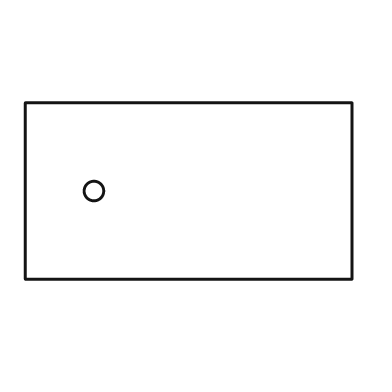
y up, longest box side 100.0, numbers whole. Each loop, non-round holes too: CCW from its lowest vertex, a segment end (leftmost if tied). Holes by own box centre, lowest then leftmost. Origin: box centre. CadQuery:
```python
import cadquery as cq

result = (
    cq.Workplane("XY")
    .moveTo(-50.0, -27.0)
    .lineTo(50.0, -27.0)
    .lineTo(50.0, 27.0)
    .lineTo(-50.0, 27.0)
    .close()
    .moveTo(-29.0, 0.0)
    .circle(3.0)
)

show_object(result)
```